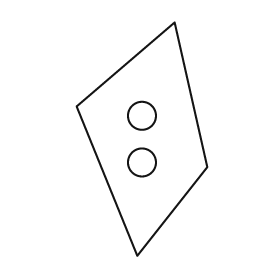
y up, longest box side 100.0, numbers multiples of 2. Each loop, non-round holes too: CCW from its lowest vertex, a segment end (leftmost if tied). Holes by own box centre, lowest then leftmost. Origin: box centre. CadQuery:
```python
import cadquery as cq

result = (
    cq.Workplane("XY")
    .moveTo(-2.0, -50.0)
    .lineTo(28.0, -12.0)
    .lineTo(14.0, 50.0)
    .lineTo(-28.0, 14.0)
    .close()
    .moveTo(0.0, -10.0)
    .circle(6.0)
    .moveTo(0.0, 10.0)
    .circle(6.0)
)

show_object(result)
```